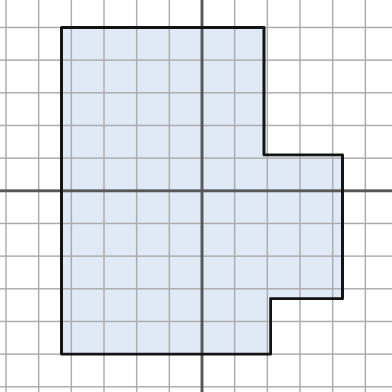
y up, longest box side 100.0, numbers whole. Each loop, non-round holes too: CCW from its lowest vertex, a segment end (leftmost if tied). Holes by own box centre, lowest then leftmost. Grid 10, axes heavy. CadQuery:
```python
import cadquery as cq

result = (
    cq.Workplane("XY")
    .moveTo(-43.0, -50.0)
    .lineTo(21.0, -50.0)
    .lineTo(21.0, -33.0)
    .lineTo(43.0, -33.0)
    .lineTo(43.0, 11.0)
    .lineTo(19.0, 11.0)
    .lineTo(19.0, 50.0)
    .lineTo(-43.0, 50.0)
    .close()
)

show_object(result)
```